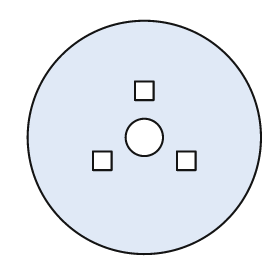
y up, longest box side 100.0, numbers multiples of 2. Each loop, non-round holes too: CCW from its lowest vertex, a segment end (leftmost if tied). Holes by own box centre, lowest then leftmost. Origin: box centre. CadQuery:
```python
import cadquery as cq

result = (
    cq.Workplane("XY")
    .moveTo(0.0, 0.0)
    .circle(50.0)
    .moveTo(-22.0, -14.0)
    .lineTo(-14.0, -14.0)
    .lineTo(-14.0, -6.0)
    .lineTo(-22.0, -6.0)
    .close()
    .moveTo(14.0, -14.0)
    .lineTo(22.0, -14.0)
    .lineTo(22.0, -6.0)
    .lineTo(14.0, -6.0)
    .close()
    .moveTo(0.0, 0.0)
    .circle(8.0)
    .moveTo(-4.0, 16.0)
    .lineTo(4.0, 16.0)
    .lineTo(4.0, 24.0)
    .lineTo(-4.0, 24.0)
    .close()
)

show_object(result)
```